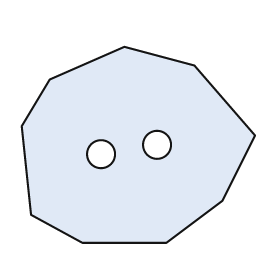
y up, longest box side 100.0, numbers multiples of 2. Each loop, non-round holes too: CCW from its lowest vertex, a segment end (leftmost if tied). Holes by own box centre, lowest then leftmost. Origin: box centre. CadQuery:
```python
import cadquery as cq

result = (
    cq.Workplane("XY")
    .moveTo(-24.0, -42.0)
    .lineTo(12.0, -42.0)
    .lineTo(36.0, -24.0)
    .lineTo(50.0, 4.0)
    .lineTo(24.0, 34.0)
    .lineTo(-6.0, 42.0)
    .lineTo(-38.0, 28.0)
    .lineTo(-50.0, 8.0)
    .lineTo(-46.0, -30.0)
    .close()
    .moveTo(-16.0, -4.0)
    .circle(6.0)
    .moveTo(8.0, 0.0)
    .circle(6.0)
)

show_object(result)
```